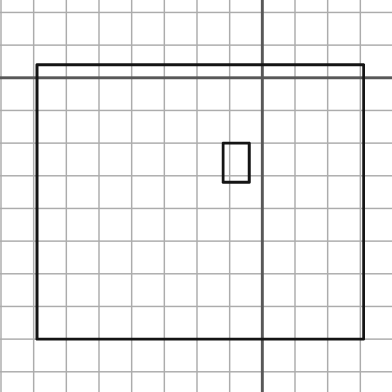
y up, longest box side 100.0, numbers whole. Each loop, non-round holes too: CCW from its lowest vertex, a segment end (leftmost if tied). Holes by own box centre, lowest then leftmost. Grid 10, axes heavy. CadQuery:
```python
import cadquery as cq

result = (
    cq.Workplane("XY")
    .moveTo(-69.0, -80.0)
    .lineTo(31.0, -80.0)
    .lineTo(31.0, 4.0)
    .lineTo(-69.0, 4.0)
    .close()
    .moveTo(-12.0, -32.0)
    .lineTo(-4.0, -32.0)
    .lineTo(-4.0, -20.0)
    .lineTo(-12.0, -20.0)
    .close()
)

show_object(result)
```